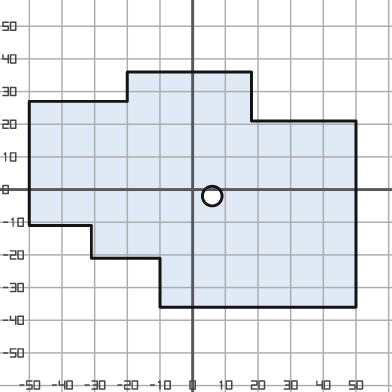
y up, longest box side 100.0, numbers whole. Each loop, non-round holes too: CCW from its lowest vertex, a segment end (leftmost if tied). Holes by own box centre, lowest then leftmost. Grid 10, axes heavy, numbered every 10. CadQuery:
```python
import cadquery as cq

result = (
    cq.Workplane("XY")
    .moveTo(-10.0, -36.0)
    .lineTo(50.0, -36.0)
    .lineTo(50.0, 21.0)
    .lineTo(18.0, 21.0)
    .lineTo(18.0, 36.0)
    .lineTo(-20.0, 36.0)
    .lineTo(-20.0, 27.0)
    .lineTo(-50.0, 27.0)
    .lineTo(-50.0, -11.0)
    .lineTo(-31.0, -11.0)
    .lineTo(-31.0, -21.0)
    .lineTo(-10.0, -21.0)
    .close()
    .moveTo(6.0, -2.0)
    .circle(3.0)
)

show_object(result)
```